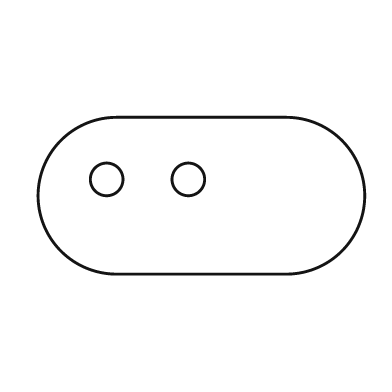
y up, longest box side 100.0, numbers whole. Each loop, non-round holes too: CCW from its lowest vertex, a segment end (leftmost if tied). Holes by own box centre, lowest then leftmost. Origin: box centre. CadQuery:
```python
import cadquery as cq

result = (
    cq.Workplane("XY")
    .moveTo(-26.0, -24.0)
    .lineTo(26.0, -24.0)
    .threePointArc((50.0, 0.0), (26.0, 24.0))
    .lineTo(-26.0, 24.0)
    .threePointArc((-50.0, 0.0), (-26.0, -24.0))
    .close()
    .moveTo(-29.0, 5.0)
    .circle(5.0)
    .moveTo(-4.0, 5.0)
    .circle(5.0)
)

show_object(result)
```